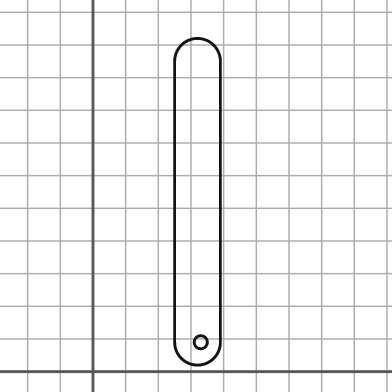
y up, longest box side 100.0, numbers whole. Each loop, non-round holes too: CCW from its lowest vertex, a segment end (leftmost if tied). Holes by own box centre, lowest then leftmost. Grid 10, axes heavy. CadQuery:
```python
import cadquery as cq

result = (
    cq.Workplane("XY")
    .moveTo(25.0, 9.0)
    .threePointArc((32.0, 2.0), (39.0, 9.0))
    .lineTo(39.0, 95.0)
    .threePointArc((32.0, 102.0), (25.0, 95.0))
    .close()
    .moveTo(33.0, 9.0)
    .circle(2.0)
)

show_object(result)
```